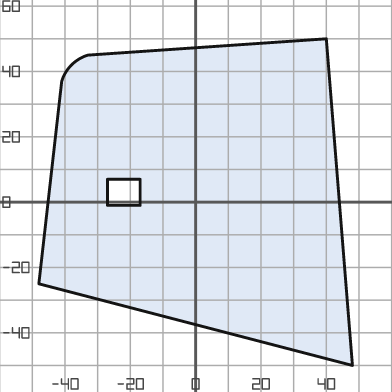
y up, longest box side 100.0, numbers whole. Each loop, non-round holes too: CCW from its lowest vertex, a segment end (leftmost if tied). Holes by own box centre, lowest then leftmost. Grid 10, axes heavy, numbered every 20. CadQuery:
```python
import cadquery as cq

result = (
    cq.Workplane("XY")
    .moveTo(48.0, -50.0)
    .lineTo(40.0, 50.0)
    .lineTo(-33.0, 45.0)
    .threePointArc((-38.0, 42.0), (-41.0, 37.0))
    .lineTo(-48.0, -25.0)
    .close()
    .moveTo(-27.0, -1.0)
    .lineTo(-17.0, -1.0)
    .lineTo(-17.0, 7.0)
    .lineTo(-27.0, 7.0)
    .close()
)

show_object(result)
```